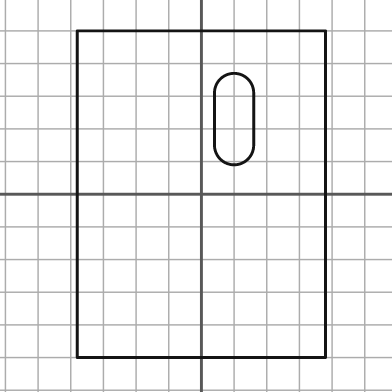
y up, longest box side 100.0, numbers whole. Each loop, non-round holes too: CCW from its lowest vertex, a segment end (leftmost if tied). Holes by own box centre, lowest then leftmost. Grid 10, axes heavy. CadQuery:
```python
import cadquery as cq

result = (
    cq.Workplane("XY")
    .moveTo(-38.0, -50.0)
    .lineTo(38.0, -50.0)
    .lineTo(38.0, 50.0)
    .lineTo(-38.0, 50.0)
    .close()
    .moveTo(4.0, 15.0)
    .threePointArc((10.0, 9.0), (16.0, 15.0))
    .lineTo(16.0, 31.0)
    .threePointArc((10.0, 37.0), (4.0, 31.0))
    .close()
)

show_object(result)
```